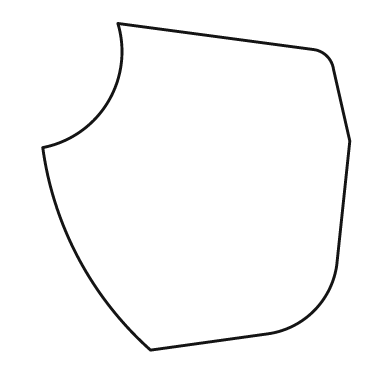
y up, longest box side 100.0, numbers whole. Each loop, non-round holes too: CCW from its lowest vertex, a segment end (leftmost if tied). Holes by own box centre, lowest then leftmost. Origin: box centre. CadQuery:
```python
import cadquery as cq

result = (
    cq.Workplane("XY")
    .moveTo(-14.0, -50.0)
    .lineTo(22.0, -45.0)
    .threePointArc((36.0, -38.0), (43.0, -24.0))
    .lineTo(47.0, 14.0)
    .lineTo(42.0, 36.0)
    .threePointArc((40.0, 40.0), (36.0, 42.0))
    .lineTo(-24.0, 50.0)
    .threePointArc((-27.0, 26.0), (-47.0, 12.0))
    .threePointArc((-36.0, -22.0), (-14.0, -50.0))
    .close()
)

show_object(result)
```